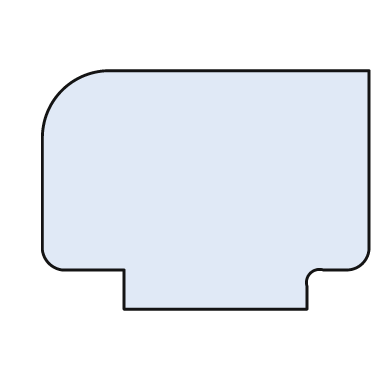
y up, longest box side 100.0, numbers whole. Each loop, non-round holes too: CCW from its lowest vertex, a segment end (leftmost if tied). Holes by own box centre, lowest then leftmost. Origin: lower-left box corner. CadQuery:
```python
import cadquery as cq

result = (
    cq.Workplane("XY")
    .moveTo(25.0, 0.0)
    .lineTo(81.0, 0.0)
    .lineTo(81.0, 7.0)
    .threePointArc((82.0, 11.0), (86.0, 12.0))
    .lineTo(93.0, 12.0)
    .threePointArc((98.0, 14.0), (100.0, 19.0))
    .lineTo(100.0, 73.0)
    .lineTo(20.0, 73.0)
    .threePointArc((6.0, 67.0), (0.0, 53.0))
    .lineTo(0.0, 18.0)
    .threePointArc((2.0, 14.0), (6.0, 12.0))
    .lineTo(25.0, 12.0)
    .close()
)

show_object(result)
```